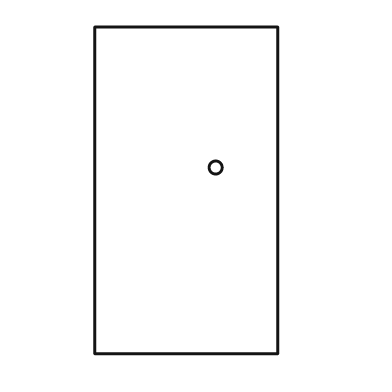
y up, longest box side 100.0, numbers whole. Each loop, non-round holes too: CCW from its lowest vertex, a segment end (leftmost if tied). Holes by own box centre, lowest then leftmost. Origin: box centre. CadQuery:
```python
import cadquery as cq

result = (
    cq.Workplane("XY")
    .moveTo(-28.0, -50.0)
    .lineTo(28.0, -50.0)
    .lineTo(28.0, 50.0)
    .lineTo(-28.0, 50.0)
    .close()
    .moveTo(9.0, 7.0)
    .circle(2.0)
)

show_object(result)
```